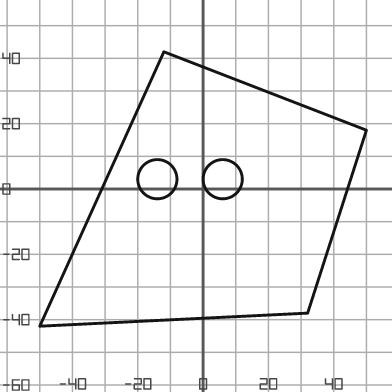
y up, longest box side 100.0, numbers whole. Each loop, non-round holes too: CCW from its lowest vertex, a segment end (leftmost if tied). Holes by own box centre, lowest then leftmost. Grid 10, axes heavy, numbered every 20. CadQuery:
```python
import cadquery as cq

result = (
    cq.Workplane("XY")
    .moveTo(-50.0, -42.0)
    .lineTo(32.0, -38.0)
    .lineTo(50.0, 18.0)
    .lineTo(-12.0, 42.0)
    .close()
    .moveTo(-14.0, 3.0)
    .circle(6.0)
    .moveTo(6.0, 3.0)
    .circle(6.0)
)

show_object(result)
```